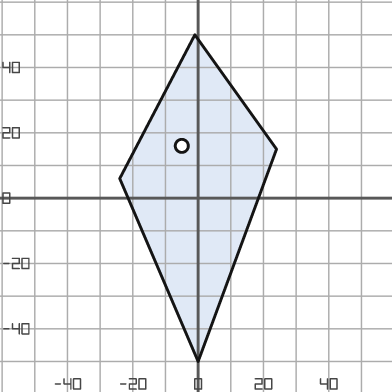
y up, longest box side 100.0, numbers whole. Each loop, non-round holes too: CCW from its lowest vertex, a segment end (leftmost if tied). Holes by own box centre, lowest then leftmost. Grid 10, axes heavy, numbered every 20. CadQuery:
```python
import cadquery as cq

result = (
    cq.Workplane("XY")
    .moveTo(0.0, -50.0)
    .lineTo(24.0, 15.0)
    .lineTo(-1.0, 50.0)
    .lineTo(-24.0, 6.0)
    .close()
    .moveTo(-5.0, 16.0)
    .circle(2.0)
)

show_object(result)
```